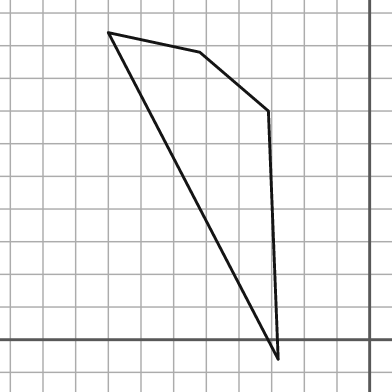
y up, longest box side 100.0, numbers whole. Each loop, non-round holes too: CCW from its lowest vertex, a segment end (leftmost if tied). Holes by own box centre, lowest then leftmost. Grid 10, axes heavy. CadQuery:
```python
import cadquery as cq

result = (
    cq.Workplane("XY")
    .moveTo(-28.0, -6.0)
    .lineTo(-31.0, 70.0)
    .lineTo(-52.0, 88.0)
    .lineTo(-80.0, 94.0)
    .close()
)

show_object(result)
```